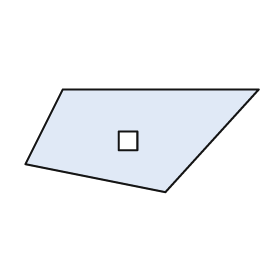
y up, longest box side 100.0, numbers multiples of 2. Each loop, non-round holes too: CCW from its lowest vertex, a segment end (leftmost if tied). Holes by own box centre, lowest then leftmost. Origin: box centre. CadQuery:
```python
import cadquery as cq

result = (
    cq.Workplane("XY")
    .moveTo(10.0, -22.0)
    .lineTo(50.0, 22.0)
    .lineTo(-34.0, 22.0)
    .lineTo(-50.0, -10.0)
    .close()
    .moveTo(-10.0, -4.0)
    .lineTo(-2.0, -4.0)
    .lineTo(-2.0, 4.0)
    .lineTo(-10.0, 4.0)
    .close()
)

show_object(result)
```